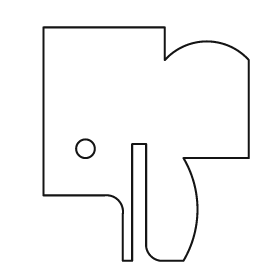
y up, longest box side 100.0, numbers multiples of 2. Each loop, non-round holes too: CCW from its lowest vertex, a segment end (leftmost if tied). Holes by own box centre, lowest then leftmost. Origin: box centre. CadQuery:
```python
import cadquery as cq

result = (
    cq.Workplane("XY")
    .moveTo(-10.0, -50.0)
    .lineTo(-6.0, -50.0)
    .lineTo(-6.0, 0.0)
    .lineTo(0.0, 0.0)
    .lineTo(0.0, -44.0)
    .threePointArc((2.0, -48.0), (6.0, -50.0))
    .lineTo(16.0, -50.0)
    .threePointArc((22.0, -28.0), (16.0, -6.0))
    .lineTo(44.0, -6.0)
    .lineTo(44.0, 36.0)
    .threePointArc((26.0, 44.0), (8.0, 36.0))
    .lineTo(8.0, 50.0)
    .lineTo(-44.0, 50.0)
    .lineTo(-44.0, -22.0)
    .lineTo(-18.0, -22.0)
    .threePointArc((-12.0, -24.0), (-10.0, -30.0))
    .close()
    .moveTo(-26.0, -2.0)
    .circle(4.0)
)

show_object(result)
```